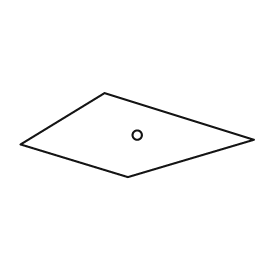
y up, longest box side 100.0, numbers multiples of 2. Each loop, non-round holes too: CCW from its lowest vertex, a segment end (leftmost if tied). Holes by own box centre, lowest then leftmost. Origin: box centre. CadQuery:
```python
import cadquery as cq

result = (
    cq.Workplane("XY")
    .moveTo(-4.0, -18.0)
    .lineTo(50.0, -2.0)
    .lineTo(-14.0, 18.0)
    .lineTo(-50.0, -4.0)
    .close()
    .moveTo(0.0, 0.0)
    .circle(2.0)
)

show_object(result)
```